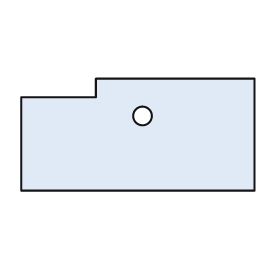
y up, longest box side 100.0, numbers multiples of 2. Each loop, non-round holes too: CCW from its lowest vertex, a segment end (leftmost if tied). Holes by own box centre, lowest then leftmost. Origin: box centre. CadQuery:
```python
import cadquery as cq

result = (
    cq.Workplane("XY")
    .moveTo(-50.0, -24.0)
    .lineTo(50.0, -24.0)
    .lineTo(50.0, 24.0)
    .lineTo(-18.0, 24.0)
    .lineTo(-18.0, 16.0)
    .lineTo(-50.0, 16.0)
    .close()
    .moveTo(2.0, 8.0)
    .circle(4.0)
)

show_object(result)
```